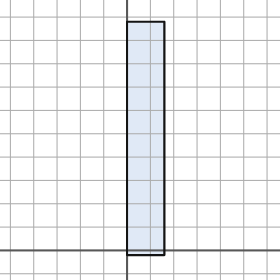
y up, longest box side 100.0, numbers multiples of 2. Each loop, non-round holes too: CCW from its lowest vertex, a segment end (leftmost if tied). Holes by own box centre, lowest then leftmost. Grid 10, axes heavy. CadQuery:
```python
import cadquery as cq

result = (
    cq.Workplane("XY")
    .moveTo(0.0, -2.0)
    .lineTo(16.0, -2.0)
    .lineTo(16.0, 98.0)
    .lineTo(0.0, 98.0)
    .close()
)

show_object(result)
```